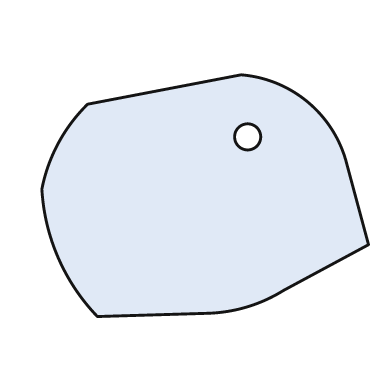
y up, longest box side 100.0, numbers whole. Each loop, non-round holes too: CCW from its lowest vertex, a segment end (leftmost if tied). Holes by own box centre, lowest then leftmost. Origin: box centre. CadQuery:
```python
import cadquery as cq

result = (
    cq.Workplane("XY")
    .moveTo(-33.0, -37.0)
    .lineTo(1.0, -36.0)
    .threePointArc((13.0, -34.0), (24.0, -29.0))
    .lineTo(50.0, -15.0)
    .lineTo(43.0, 11.0)
    .threePointArc((31.0, 29.0), (11.0, 37.0))
    .lineTo(-36.0, 28.0)
    .threePointArc((-45.0, 16.0), (-50.0, 2.0))
    .threePointArc((-45.0, -19.0), (-33.0, -37.0))
    .close()
    .moveTo(13.0, 18.0)
    .circle(4.0)
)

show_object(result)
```